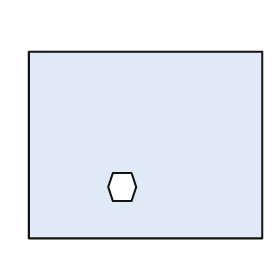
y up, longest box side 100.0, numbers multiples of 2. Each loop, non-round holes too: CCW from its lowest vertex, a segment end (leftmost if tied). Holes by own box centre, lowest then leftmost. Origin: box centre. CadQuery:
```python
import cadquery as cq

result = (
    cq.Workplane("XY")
    .moveTo(-50.0, -40.0)
    .lineTo(50.0, -40.0)
    .lineTo(50.0, 40.0)
    .lineTo(-50.0, 40.0)
    .close()
    .moveTo(-14.0, -24.0)
    .lineTo(-6.0, -24.0)
    .lineTo(-4.0, -18.0)
    .lineTo(-6.0, -12.0)
    .lineTo(-14.0, -12.0)
    .lineTo(-16.0, -18.0)
    .close()
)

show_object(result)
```